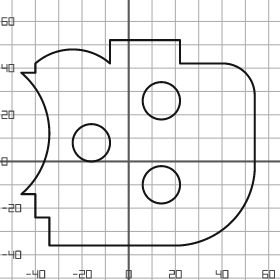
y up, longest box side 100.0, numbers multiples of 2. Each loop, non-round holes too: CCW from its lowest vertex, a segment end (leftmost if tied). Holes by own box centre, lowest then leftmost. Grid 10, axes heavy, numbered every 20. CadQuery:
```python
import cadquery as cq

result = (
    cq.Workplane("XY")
    .moveTo(-34.0, -36.0)
    .lineTo(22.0, -36.0)
    .threePointArc((44.0, -26.0), (54.0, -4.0))
    .lineTo(54.0, 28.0)
    .threePointArc((50.0, 38.0), (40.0, 42.0))
    .lineTo(22.0, 42.0)
    .lineTo(22.0, 52.0)
    .lineTo(-8.0, 52.0)
    .lineTo(-8.0, 42.0)
    .threePointArc((-24.0, 48.0), (-40.0, 42.0))
    .lineTo(-40.0, 38.0)
    .lineTo(-46.0, 38.0)
    .threePointArc((-34.0, 12.0), (-46.0, -14.0))
    .lineTo(-40.0, -14.0)
    .lineTo(-40.0, -24.0)
    .lineTo(-34.0, -24.0)
    .close()
    .moveTo(14.0, -10.0)
    .circle(8.0)
    .moveTo(-16.0, 8.0)
    .circle(8.0)
    .moveTo(14.0, 26.0)
    .circle(8.0)
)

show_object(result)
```